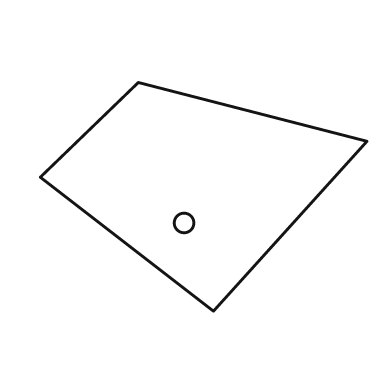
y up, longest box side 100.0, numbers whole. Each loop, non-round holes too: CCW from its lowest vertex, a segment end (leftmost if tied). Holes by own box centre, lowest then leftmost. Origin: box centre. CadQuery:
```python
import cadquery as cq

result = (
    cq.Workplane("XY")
    .moveTo(3.0, -35.0)
    .lineTo(50.0, 17.0)
    .lineTo(-20.0, 35.0)
    .lineTo(-50.0, 6.0)
    .close()
    .moveTo(-6.0, -8.0)
    .circle(3.0)
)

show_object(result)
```